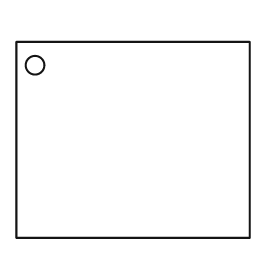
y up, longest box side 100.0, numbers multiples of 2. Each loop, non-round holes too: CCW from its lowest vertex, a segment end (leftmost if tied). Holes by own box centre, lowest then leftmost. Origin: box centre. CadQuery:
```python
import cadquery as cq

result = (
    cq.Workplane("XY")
    .moveTo(-50.0, -42.0)
    .lineTo(50.0, -42.0)
    .lineTo(50.0, 42.0)
    .lineTo(-50.0, 42.0)
    .close()
    .moveTo(-42.0, 32.0)
    .circle(4.0)
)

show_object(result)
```